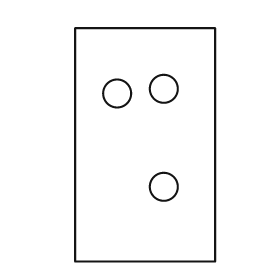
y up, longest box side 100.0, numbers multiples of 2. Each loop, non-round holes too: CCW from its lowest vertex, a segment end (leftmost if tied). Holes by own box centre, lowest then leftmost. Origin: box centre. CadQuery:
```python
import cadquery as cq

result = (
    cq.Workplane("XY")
    .moveTo(-30.0, -50.0)
    .lineTo(30.0, -50.0)
    .lineTo(30.0, 50.0)
    .lineTo(-30.0, 50.0)
    .close()
    .moveTo(8.0, -18.0)
    .circle(6.0)
    .moveTo(-12.0, 22.0)
    .circle(6.0)
    .moveTo(8.0, 24.0)
    .circle(6.0)
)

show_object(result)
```